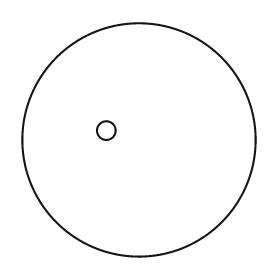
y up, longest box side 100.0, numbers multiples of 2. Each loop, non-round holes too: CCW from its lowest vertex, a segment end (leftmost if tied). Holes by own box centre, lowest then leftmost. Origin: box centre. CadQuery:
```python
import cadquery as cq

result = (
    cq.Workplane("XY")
    .moveTo(0.0, 0.0)
    .circle(50.0)
    .moveTo(-14.0, 4.0)
    .circle(4.0)
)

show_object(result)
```